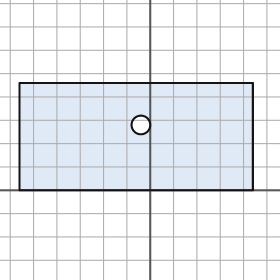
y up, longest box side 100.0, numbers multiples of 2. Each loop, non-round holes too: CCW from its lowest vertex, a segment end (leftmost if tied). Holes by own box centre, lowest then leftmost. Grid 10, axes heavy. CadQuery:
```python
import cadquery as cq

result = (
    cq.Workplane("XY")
    .moveTo(-56.0, 0.0)
    .lineTo(44.0, 0.0)
    .lineTo(44.0, 46.0)
    .lineTo(-56.0, 46.0)
    .close()
    .moveTo(-4.0, 28.0)
    .circle(4.0)
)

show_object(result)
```